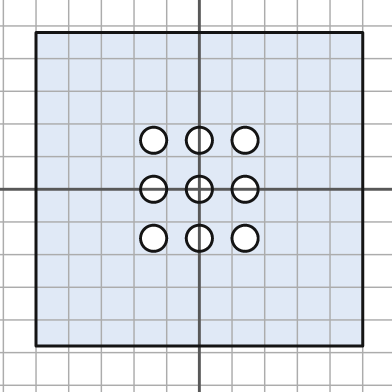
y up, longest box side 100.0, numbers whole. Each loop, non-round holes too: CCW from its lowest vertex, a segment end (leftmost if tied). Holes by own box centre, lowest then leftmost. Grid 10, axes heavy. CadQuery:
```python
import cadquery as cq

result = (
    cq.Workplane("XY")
    .moveTo(-50.0, -48.0)
    .lineTo(50.0, -48.0)
    .lineTo(50.0, 48.0)
    .lineTo(-50.0, 48.0)
    .close()
    .moveTo(-14.0, -15.0)
    .circle(4.0)
    .moveTo(0.0, -15.0)
    .circle(4.0)
    .moveTo(14.0, -15.0)
    .circle(4.0)
    .moveTo(-14.0, 0.0)
    .circle(4.0)
    .moveTo(0.0, 0.0)
    .circle(4.0)
    .moveTo(14.0, 0.0)
    .circle(4.0)
    .moveTo(-14.0, 15.0)
    .circle(4.0)
    .moveTo(0.0, 15.0)
    .circle(4.0)
    .moveTo(14.0, 15.0)
    .circle(4.0)
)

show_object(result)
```